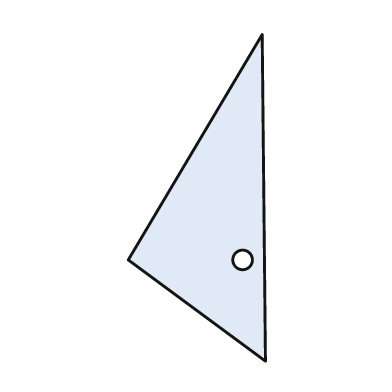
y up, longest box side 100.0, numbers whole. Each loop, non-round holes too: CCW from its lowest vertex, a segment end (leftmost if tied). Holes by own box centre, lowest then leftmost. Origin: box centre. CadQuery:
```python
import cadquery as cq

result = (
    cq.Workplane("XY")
    .moveTo(21.0, -50.0)
    .lineTo(20.0, 50.0)
    .lineTo(-21.0, -19.0)
    .close()
    .moveTo(14.0, -19.0)
    .circle(3.0)
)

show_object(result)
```